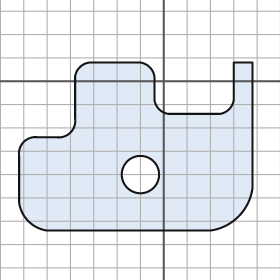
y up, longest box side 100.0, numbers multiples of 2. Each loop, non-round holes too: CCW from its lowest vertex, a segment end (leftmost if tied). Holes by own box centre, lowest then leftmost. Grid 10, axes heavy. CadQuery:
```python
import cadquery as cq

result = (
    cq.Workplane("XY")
    .moveTo(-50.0, -64.0)
    .lineTo(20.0, -64.0)
    .threePointArc((32.0, -58.0), (38.0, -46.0))
    .lineTo(38.0, 8.0)
    .lineTo(30.0, 8.0)
    .lineTo(30.0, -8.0)
    .threePointArc((28.0, -12.0), (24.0, -14.0))
    .lineTo(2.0, -14.0)
    .threePointArc((-2.0, -12.0), (-4.0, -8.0))
    .lineTo(-4.0, 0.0)
    .threePointArc((-6.0, 6.0), (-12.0, 8.0))
    .lineTo(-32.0, 8.0)
    .threePointArc((-36.0, 6.0), (-38.0, 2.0))
    .lineTo(-38.0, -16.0)
    .threePointArc((-40.0, -22.0), (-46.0, -24.0))
    .lineTo(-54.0, -24.0)
    .threePointArc((-60.0, -26.0), (-62.0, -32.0))
    .lineTo(-62.0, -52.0)
    .threePointArc((-58.0, -60.0), (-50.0, -64.0))
    .close()
    .moveTo(-10.0, -40.0)
    .circle(8.0)
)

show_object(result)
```